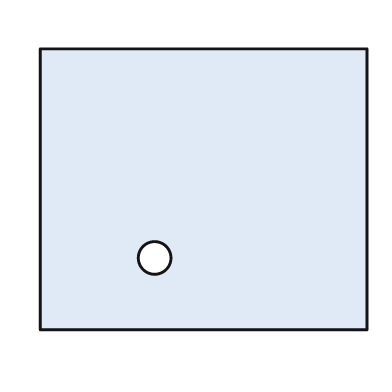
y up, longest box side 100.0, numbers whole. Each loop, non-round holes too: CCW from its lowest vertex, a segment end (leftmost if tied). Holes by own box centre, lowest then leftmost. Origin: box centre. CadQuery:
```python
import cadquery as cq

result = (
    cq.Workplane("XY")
    .moveTo(-50.0, -43.0)
    .lineTo(50.0, -43.0)
    .lineTo(50.0, 43.0)
    .lineTo(-50.0, 43.0)
    .close()
    .moveTo(-15.0, -21.0)
    .circle(5.0)
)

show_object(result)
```